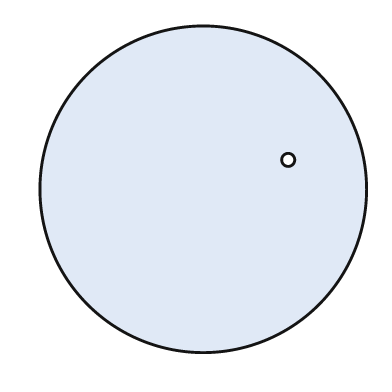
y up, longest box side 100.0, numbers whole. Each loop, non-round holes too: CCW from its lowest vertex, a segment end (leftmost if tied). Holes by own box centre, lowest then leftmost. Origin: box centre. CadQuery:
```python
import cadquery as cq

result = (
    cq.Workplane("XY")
    .moveTo(0.0, 0.0)
    .circle(50.0)
    .moveTo(26.0, 9.0)
    .circle(2.0)
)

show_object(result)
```